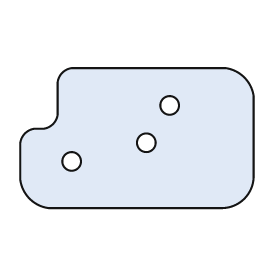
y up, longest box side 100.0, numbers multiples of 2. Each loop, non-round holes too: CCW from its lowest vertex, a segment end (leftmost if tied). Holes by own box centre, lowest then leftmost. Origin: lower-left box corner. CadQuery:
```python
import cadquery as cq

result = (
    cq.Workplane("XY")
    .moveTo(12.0, 0.0)
    .lineTo(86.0, 0.0)
    .threePointArc((96.0, 4.0), (100.0, 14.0))
    .lineTo(100.0, 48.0)
    .threePointArc((96.0, 56.0), (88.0, 60.0))
    .lineTo(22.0, 60.0)
    .threePointArc((18.0, 58.0), (16.0, 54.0))
    .lineTo(16.0, 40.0)
    .threePointArc((14.0, 36.0), (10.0, 34.0))
    .lineTo(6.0, 34.0)
    .threePointArc((2.0, 32.0), (0.0, 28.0))
    .lineTo(0.0, 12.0)
    .threePointArc((4.0, 4.0), (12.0, 0.0))
    .close()
    .moveTo(22.0, 20.0)
    .circle(4.0)
    .moveTo(54.0, 28.0)
    .circle(4.0)
    .moveTo(64.0, 44.0)
    .circle(4.0)
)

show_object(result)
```